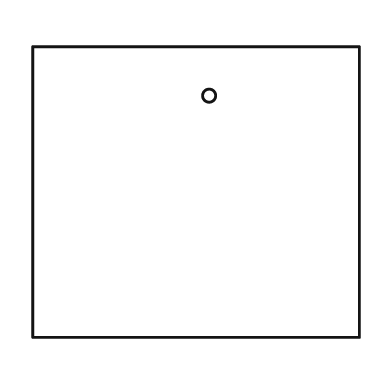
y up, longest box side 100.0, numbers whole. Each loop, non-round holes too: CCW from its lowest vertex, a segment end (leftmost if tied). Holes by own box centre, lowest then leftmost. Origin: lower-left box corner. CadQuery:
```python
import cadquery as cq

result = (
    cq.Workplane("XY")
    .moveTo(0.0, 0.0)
    .lineTo(100.0, 0.0)
    .lineTo(100.0, 89.0)
    .lineTo(0.0, 89.0)
    .close()
    .moveTo(54.0, 74.0)
    .circle(2.0)
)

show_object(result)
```